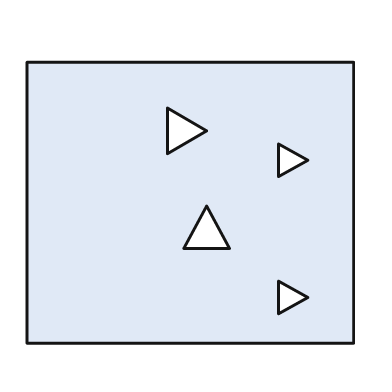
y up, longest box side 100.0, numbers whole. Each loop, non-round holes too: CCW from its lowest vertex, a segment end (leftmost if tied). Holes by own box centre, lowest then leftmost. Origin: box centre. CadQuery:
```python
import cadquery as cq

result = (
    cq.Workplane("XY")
    .moveTo(-50.0, -43.0)
    .lineTo(50.0, -43.0)
    .lineTo(50.0, 43.0)
    .lineTo(-50.0, 43.0)
    .close()
    .moveTo(27.0, -34.0)
    .lineTo(36.0, -29.0)
    .lineTo(27.0, -24.0)
    .close()
    .moveTo(-2.0, -14.0)
    .lineTo(12.0, -14.0)
    .lineTo(5.0, -1.0)
    .close()
    .moveTo(27.0, 8.0)
    .lineTo(36.0, 13.0)
    .lineTo(27.0, 18.0)
    .close()
    .moveTo(-7.0, 15.0)
    .lineTo(5.0, 22.0)
    .lineTo(-7.0, 29.0)
    .close()
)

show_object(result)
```